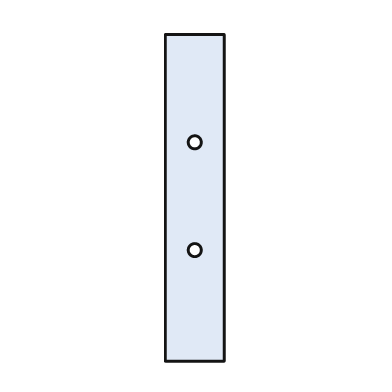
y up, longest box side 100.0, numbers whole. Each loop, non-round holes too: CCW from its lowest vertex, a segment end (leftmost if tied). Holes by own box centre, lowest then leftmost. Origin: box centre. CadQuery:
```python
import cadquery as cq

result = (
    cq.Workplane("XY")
    .moveTo(-9.0, -50.0)
    .lineTo(9.0, -50.0)
    .lineTo(9.0, 50.0)
    .lineTo(-9.0, 50.0)
    .close()
    .moveTo(0.0, -16.0)
    .circle(2.0)
    .moveTo(0.0, 17.0)
    .circle(2.0)
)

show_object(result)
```